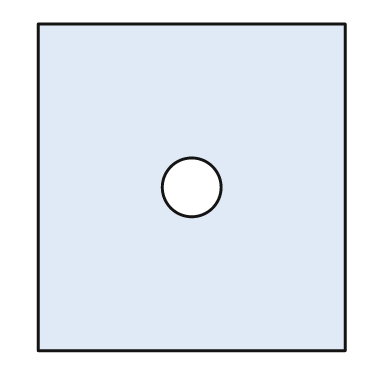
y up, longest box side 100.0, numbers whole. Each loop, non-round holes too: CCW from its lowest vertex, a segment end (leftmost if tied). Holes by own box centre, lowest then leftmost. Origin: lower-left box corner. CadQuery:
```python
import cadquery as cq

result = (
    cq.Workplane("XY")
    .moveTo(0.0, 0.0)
    .lineTo(94.0, 0.0)
    .lineTo(94.0, 100.0)
    .lineTo(0.0, 100.0)
    .close()
    .moveTo(47.0, 50.0)
    .circle(9.0)
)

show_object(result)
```